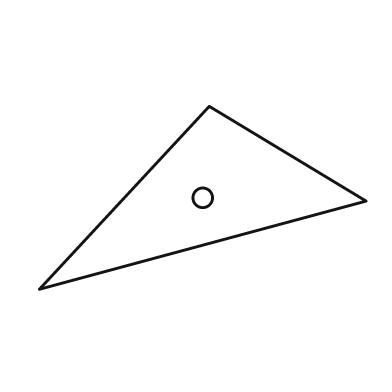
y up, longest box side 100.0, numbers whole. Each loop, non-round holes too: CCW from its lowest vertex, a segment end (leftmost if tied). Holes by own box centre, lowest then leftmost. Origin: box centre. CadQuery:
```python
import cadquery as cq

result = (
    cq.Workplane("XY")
    .moveTo(-50.0, -28.0)
    .lineTo(50.0, -1.0)
    .lineTo(2.0, 28.0)
    .close()
    .moveTo(0.0, 0.0)
    .circle(3.0)
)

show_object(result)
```